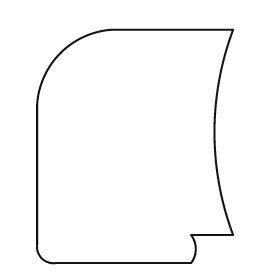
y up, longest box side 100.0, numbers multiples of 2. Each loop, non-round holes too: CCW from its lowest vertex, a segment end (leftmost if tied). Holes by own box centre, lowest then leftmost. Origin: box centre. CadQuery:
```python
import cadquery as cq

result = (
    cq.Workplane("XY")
    .moveTo(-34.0, -50.0)
    .lineTo(24.0, -50.0)
    .threePointArc((26.0, -44.0), (24.0, -38.0))
    .lineTo(42.0, -38.0)
    .threePointArc((34.0, 6.0), (42.0, 50.0))
    .lineTo(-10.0, 50.0)
    .threePointArc((-32.0, 40.0), (-42.0, 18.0))
    .lineTo(-42.0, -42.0)
    .threePointArc((-40.0, -48.0), (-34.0, -50.0))
    .close()
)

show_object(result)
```